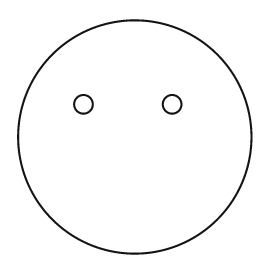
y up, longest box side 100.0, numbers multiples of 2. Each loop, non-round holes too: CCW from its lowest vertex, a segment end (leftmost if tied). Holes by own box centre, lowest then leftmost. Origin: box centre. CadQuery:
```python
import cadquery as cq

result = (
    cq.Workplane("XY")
    .moveTo(0.0, 0.0)
    .circle(50.0)
    .moveTo(-22.0, 14.0)
    .circle(4.0)
    .moveTo(16.0, 14.0)
    .circle(4.0)
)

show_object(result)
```